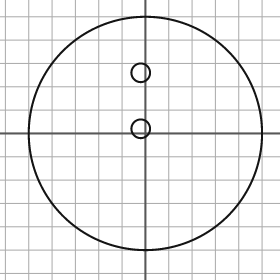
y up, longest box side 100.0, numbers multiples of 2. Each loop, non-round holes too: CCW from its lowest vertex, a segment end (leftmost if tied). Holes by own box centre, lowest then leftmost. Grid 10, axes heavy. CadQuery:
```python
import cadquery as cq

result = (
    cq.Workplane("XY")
    .moveTo(0.0, 0.0)
    .circle(50.0)
    .moveTo(-2.0, 2.0)
    .circle(4.0)
    .moveTo(-2.0, 26.0)
    .circle(4.0)
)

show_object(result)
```